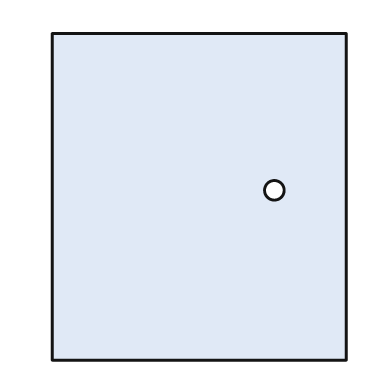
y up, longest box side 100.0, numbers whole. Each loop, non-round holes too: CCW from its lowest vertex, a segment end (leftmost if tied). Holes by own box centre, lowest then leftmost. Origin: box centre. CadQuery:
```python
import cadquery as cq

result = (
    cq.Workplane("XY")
    .moveTo(-45.0, -50.0)
    .lineTo(45.0, -50.0)
    .lineTo(45.0, 50.0)
    .lineTo(-45.0, 50.0)
    .close()
    .moveTo(23.0, 2.0)
    .circle(3.0)
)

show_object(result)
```